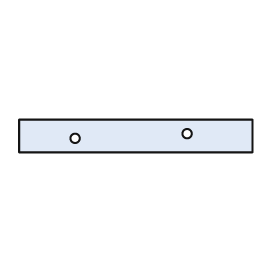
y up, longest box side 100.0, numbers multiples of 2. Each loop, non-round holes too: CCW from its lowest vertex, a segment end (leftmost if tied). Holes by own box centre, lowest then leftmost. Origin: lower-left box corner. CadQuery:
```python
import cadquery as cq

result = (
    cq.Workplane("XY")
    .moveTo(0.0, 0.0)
    .lineTo(100.0, 0.0)
    .lineTo(100.0, 14.0)
    .lineTo(0.0, 14.0)
    .close()
    .moveTo(24.0, 6.0)
    .circle(2.0)
    .moveTo(72.0, 8.0)
    .circle(2.0)
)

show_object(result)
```